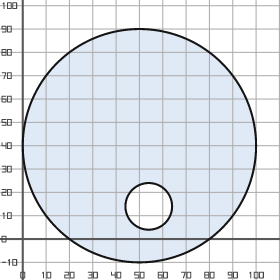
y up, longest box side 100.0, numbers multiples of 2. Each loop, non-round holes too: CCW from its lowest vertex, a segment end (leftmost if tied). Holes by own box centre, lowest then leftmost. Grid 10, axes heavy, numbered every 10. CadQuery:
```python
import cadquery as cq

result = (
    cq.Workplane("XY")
    .moveTo(50.0, 40.0)
    .circle(50.0)
    .moveTo(54.0, 14.0)
    .circle(10.0)
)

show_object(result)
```